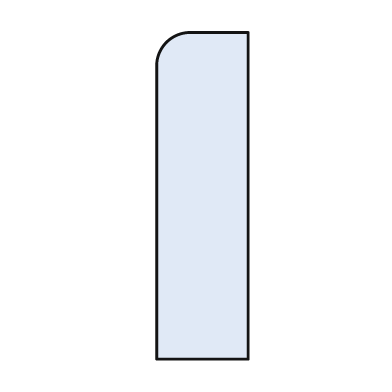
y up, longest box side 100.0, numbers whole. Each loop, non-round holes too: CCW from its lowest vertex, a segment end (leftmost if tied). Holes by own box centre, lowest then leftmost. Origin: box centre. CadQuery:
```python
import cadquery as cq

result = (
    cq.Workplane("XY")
    .moveTo(-14.0, -50.0)
    .lineTo(14.0, -50.0)
    .lineTo(14.0, 50.0)
    .lineTo(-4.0, 50.0)
    .threePointArc((-11.0, 47.0), (-14.0, 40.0))
    .close()
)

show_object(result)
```